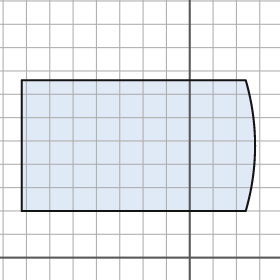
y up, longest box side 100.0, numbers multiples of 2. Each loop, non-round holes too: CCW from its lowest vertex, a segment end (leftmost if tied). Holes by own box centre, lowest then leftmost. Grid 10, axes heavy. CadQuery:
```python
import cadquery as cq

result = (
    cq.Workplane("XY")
    .moveTo(-72.0, 20.0)
    .lineTo(24.0, 20.0)
    .threePointArc((28.0, 48.0), (24.0, 76.0))
    .lineTo(-72.0, 76.0)
    .close()
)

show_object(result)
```